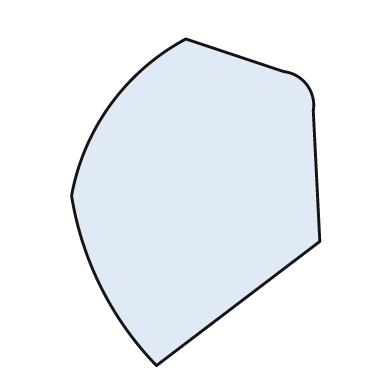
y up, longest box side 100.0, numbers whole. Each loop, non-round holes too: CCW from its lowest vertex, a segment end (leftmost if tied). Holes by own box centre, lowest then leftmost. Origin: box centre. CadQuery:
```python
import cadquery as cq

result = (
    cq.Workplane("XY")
    .moveTo(-12.0, -50.0)
    .lineTo(38.0, -12.0)
    .lineTo(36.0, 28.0)
    .threePointArc((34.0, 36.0), (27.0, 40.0))
    .lineTo(-3.0, 50.0)
    .threePointArc((-26.0, 30.0), (-38.0, 2.0))
    .threePointArc((-29.0, -26.0), (-12.0, -50.0))
    .close()
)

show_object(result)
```